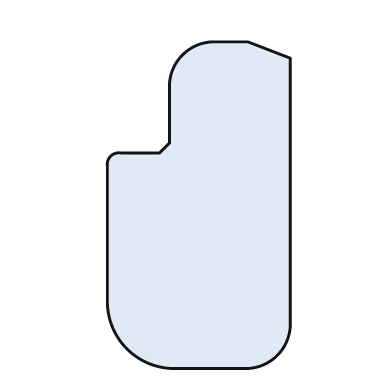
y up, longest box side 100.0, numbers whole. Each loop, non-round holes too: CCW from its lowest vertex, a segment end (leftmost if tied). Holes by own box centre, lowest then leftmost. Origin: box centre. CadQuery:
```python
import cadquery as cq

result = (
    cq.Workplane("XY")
    .moveTo(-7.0, -50.0)
    .lineTo(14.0, -50.0)
    .threePointArc((24.0, -46.0), (28.0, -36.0))
    .lineTo(28.0, 45.0)
    .lineTo(15.0, 50.0)
    .lineTo(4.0, 50.0)
    .threePointArc((-5.0, 46.0), (-9.0, 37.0))
    .lineTo(-9.0, 19.0)
    .lineTo(-12.0, 16.0)
    .lineTo(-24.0, 16.0)
    .threePointArc((-27.0, 15.0), (-28.0, 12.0))
    .lineTo(-28.0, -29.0)
    .threePointArc((-22.0, -44.0), (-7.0, -50.0))
    .close()
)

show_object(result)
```